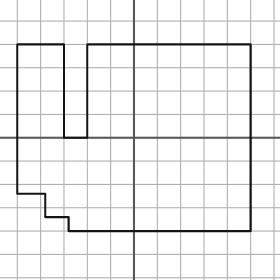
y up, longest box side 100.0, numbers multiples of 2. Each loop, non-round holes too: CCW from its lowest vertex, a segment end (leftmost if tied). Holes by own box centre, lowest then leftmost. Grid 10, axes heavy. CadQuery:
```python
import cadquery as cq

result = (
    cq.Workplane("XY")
    .moveTo(-28.0, -40.0)
    .lineTo(50.0, -40.0)
    .lineTo(50.0, 40.0)
    .lineTo(-20.0, 40.0)
    .lineTo(-20.0, 0.0)
    .lineTo(-30.0, 0.0)
    .lineTo(-30.0, 40.0)
    .lineTo(-50.0, 40.0)
    .lineTo(-50.0, -24.0)
    .lineTo(-38.0, -24.0)
    .lineTo(-38.0, -34.0)
    .lineTo(-28.0, -34.0)
    .close()
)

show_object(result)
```